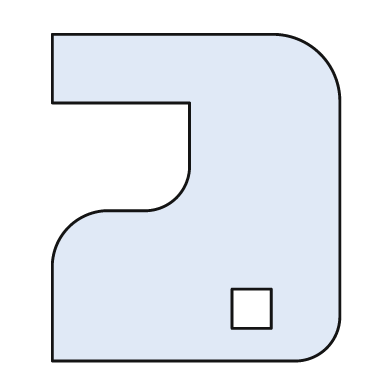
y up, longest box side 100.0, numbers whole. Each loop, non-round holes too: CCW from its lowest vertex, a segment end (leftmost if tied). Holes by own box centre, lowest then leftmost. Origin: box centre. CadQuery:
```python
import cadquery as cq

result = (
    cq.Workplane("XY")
    .moveTo(-44.0, -50.0)
    .lineTo(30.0, -50.0)
    .threePointArc((40.0, -46.0), (44.0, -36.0))
    .lineTo(44.0, 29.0)
    .threePointArc((38.0, 44.0), (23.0, 50.0))
    .lineTo(-44.0, 50.0)
    .lineTo(-44.0, 29.0)
    .lineTo(-2.0, 29.0)
    .lineTo(-2.0, 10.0)
    .threePointArc((-6.0, 0.0), (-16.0, -4.0))
    .lineTo(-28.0, -4.0)
    .threePointArc((-39.0, -9.0), (-44.0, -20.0))
    .close()
    .moveTo(11.0, -40.0)
    .lineTo(23.0, -40.0)
    .lineTo(23.0, -28.0)
    .lineTo(11.0, -28.0)
    .close()
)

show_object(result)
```